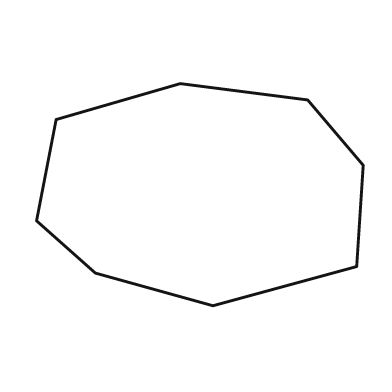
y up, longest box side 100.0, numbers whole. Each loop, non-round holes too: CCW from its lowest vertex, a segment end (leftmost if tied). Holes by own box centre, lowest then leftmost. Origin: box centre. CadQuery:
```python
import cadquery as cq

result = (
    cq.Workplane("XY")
    .moveTo(4.0, -34.0)
    .lineTo(48.0, -22.0)
    .lineTo(50.0, 9.0)
    .lineTo(33.0, 29.0)
    .lineTo(-6.0, 34.0)
    .lineTo(-44.0, 23.0)
    .lineTo(-50.0, -8.0)
    .lineTo(-32.0, -24.0)
    .close()
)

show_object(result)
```